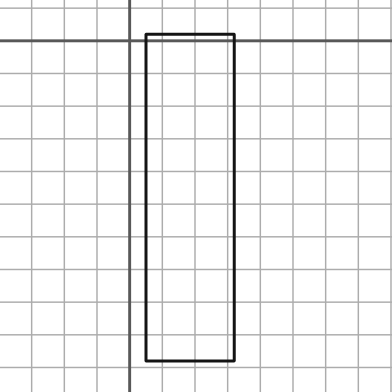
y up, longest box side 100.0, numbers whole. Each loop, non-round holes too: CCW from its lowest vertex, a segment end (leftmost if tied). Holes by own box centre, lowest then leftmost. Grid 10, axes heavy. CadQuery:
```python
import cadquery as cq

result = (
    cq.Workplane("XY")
    .moveTo(5.0, -98.0)
    .lineTo(32.0, -98.0)
    .lineTo(32.0, 2.0)
    .lineTo(5.0, 2.0)
    .close()
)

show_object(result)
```